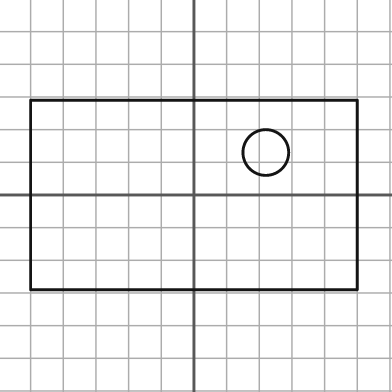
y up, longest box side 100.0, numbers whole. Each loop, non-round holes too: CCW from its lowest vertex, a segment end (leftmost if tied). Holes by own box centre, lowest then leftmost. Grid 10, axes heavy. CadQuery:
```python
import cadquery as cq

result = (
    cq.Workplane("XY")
    .moveTo(-50.0, -29.0)
    .lineTo(50.0, -29.0)
    .lineTo(50.0, 29.0)
    .lineTo(-50.0, 29.0)
    .close()
    .moveTo(22.0, 13.0)
    .circle(7.0)
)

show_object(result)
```